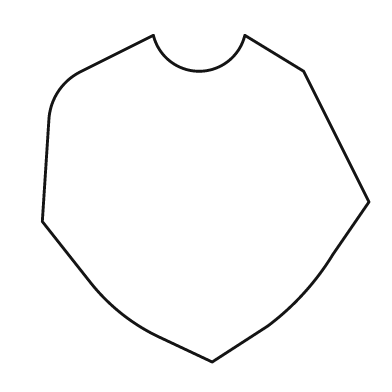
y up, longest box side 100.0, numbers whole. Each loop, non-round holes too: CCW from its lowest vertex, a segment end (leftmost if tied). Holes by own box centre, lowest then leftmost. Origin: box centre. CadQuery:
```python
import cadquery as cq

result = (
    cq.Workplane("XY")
    .moveTo(2.0, -50.0)
    .lineTo(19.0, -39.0)
    .threePointArc((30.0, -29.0), (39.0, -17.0))
    .lineTo(50.0, -1.0)
    .lineTo(30.0, 39.0)
    .lineTo(12.0, 50.0)
    .threePointArc((-2.0, 39.0), (-16.0, 50.0))
    .lineTo(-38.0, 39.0)
    .threePointArc((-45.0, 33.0), (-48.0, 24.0))
    .lineTo(-50.0, -7.0)
    .lineTo(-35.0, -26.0)
    .threePointArc((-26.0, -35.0), (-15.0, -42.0))
    .close()
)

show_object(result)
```